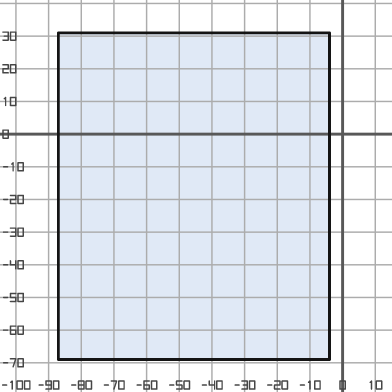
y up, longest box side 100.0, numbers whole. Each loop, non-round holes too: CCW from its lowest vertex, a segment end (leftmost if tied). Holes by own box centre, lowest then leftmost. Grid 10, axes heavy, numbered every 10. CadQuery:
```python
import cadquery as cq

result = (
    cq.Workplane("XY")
    .moveTo(-87.0, -69.0)
    .lineTo(-4.0, -69.0)
    .lineTo(-4.0, 31.0)
    .lineTo(-87.0, 31.0)
    .close()
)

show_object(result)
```